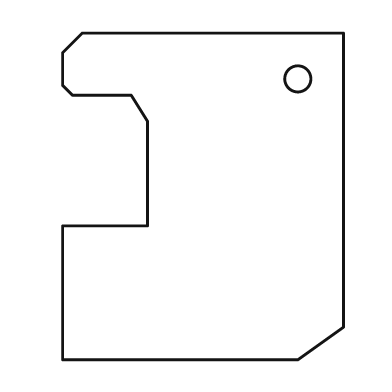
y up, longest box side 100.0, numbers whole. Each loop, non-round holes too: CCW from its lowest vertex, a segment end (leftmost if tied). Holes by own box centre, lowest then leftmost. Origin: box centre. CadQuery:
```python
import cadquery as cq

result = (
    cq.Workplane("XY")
    .moveTo(-43.0, -50.0)
    .lineTo(29.0, -50.0)
    .lineTo(43.0, -40.0)
    .lineTo(43.0, 50.0)
    .lineTo(-37.0, 50.0)
    .lineTo(-43.0, 44.0)
    .lineTo(-43.0, 34.0)
    .lineTo(-40.0, 31.0)
    .lineTo(-22.0, 31.0)
    .lineTo(-17.0, 23.0)
    .lineTo(-17.0, -9.0)
    .lineTo(-43.0, -9.0)
    .close()
    .moveTo(29.0, 36.0)
    .circle(4.0)
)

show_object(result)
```